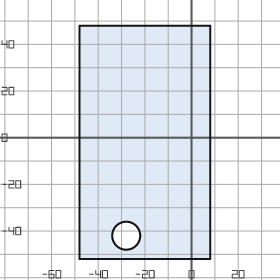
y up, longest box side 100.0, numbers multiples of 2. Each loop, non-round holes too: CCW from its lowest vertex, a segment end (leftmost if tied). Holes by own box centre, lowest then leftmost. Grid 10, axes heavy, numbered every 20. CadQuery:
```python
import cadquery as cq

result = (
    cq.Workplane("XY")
    .moveTo(-48.0, -52.0)
    .lineTo(8.0, -52.0)
    .lineTo(8.0, 48.0)
    .lineTo(-48.0, 48.0)
    .close()
    .moveTo(-28.0, -42.0)
    .circle(6.0)
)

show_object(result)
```